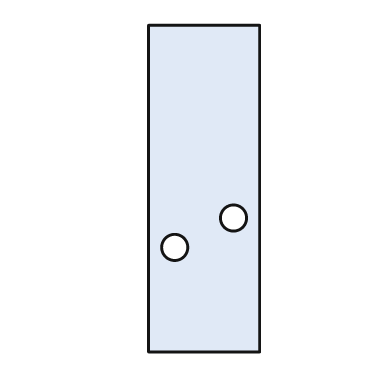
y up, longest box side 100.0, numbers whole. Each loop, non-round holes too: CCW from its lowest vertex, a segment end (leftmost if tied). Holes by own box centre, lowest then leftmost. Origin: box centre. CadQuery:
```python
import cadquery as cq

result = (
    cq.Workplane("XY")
    .moveTo(-17.0, -50.0)
    .lineTo(17.0, -50.0)
    .lineTo(17.0, 50.0)
    .lineTo(-17.0, 50.0)
    .close()
    .moveTo(-9.0, -18.0)
    .circle(4.0)
    .moveTo(9.0, -9.0)
    .circle(4.0)
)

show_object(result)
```